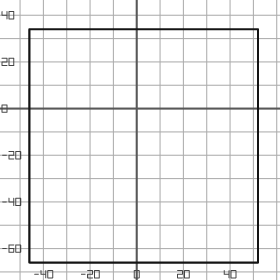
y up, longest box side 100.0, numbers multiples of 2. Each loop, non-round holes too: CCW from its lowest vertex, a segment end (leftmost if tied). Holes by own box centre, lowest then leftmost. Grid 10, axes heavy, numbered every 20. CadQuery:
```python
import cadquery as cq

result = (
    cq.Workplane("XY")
    .moveTo(-46.0, -66.0)
    .lineTo(52.0, -66.0)
    .lineTo(52.0, 34.0)
    .lineTo(-46.0, 34.0)
    .close()
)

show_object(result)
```